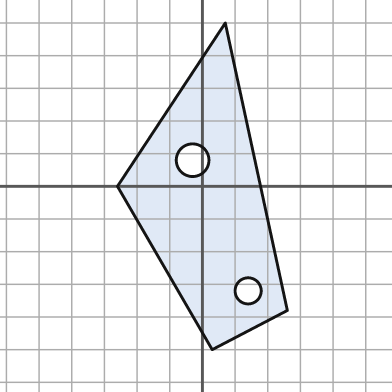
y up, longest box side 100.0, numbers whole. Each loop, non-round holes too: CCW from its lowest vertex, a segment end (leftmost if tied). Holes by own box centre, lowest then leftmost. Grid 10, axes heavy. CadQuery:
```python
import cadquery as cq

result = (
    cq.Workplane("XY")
    .moveTo(3.0, -50.0)
    .lineTo(26.0, -38.0)
    .lineTo(7.0, 50.0)
    .lineTo(-26.0, 0.0)
    .close()
    .moveTo(14.0, -32.0)
    .circle(4.0)
    .moveTo(-3.0, 8.0)
    .circle(5.0)
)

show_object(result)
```